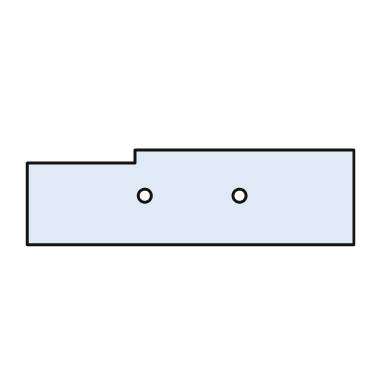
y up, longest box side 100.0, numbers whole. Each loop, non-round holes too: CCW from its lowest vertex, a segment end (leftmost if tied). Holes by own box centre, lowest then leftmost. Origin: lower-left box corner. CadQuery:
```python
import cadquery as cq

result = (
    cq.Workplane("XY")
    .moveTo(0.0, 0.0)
    .lineTo(100.0, 0.0)
    .lineTo(100.0, 29.0)
    .lineTo(33.0, 29.0)
    .lineTo(33.0, 25.0)
    .lineTo(0.0, 25.0)
    .close()
    .moveTo(36.0, 15.0)
    .circle(2.0)
    .moveTo(65.0, 15.0)
    .circle(2.0)
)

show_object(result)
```